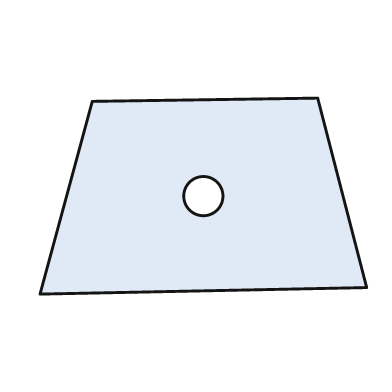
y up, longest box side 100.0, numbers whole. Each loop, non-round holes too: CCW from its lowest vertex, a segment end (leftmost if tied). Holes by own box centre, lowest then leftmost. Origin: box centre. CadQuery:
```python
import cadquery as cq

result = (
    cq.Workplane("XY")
    .moveTo(-50.0, -30.0)
    .lineTo(50.0, -28.0)
    .lineTo(35.0, 30.0)
    .lineTo(-34.0, 29.0)
    .close()
    .moveTo(0.0, 0.0)
    .circle(6.0)
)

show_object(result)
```